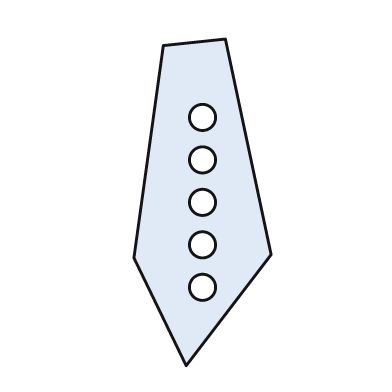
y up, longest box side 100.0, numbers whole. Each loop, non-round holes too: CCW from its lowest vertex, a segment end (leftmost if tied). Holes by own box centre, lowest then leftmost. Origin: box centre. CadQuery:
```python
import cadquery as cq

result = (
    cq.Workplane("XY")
    .moveTo(-5.0, -50.0)
    .lineTo(21.0, -16.0)
    .lineTo(7.0, 50.0)
    .lineTo(-12.0, 48.0)
    .lineTo(-21.0, -17.0)
    .close()
    .moveTo(0.0, -26.0)
    .circle(4.0)
    .moveTo(0.0, -13.0)
    .circle(4.0)
    .moveTo(0.0, 0.0)
    .circle(4.0)
    .moveTo(0.0, 13.0)
    .circle(4.0)
    .moveTo(0.0, 26.0)
    .circle(4.0)
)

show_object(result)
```